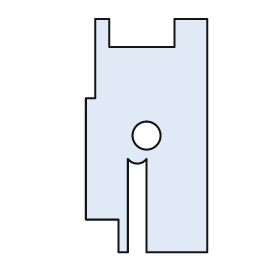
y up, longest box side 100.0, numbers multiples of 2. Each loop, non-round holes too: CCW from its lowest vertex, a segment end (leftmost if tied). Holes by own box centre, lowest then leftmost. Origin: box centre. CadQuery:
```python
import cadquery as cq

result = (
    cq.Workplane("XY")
    .moveTo(-12.0, -50.0)
    .lineTo(-8.0, -50.0)
    .lineTo(-8.0, -10.0)
    .threePointArc((-4.0, -12.0), (0.0, -10.0))
    .lineTo(0.0, -50.0)
    .lineTo(26.0, -50.0)
    .lineTo(26.0, 50.0)
    .lineTo(12.0, 50.0)
    .lineTo(12.0, 38.0)
    .lineTo(-16.0, 38.0)
    .lineTo(-16.0, 50.0)
    .lineTo(-22.0, 50.0)
    .lineTo(-22.0, 16.0)
    .lineTo(-26.0, 16.0)
    .lineTo(-26.0, -36.0)
    .lineTo(-12.0, -36.0)
    .close()
    .moveTo(0.0, 0.0)
    .circle(6.0)
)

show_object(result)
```